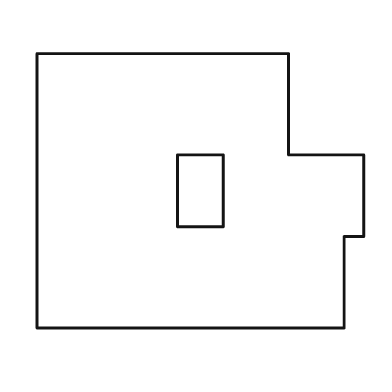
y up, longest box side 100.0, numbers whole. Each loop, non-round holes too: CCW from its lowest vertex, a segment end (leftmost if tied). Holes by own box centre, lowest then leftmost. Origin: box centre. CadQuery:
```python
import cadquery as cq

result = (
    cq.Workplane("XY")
    .moveTo(-50.0, -42.0)
    .lineTo(44.0, -42.0)
    .lineTo(44.0, -14.0)
    .lineTo(50.0, -14.0)
    .lineTo(50.0, 11.0)
    .lineTo(27.0, 11.0)
    .lineTo(27.0, 42.0)
    .lineTo(-50.0, 42.0)
    .close()
    .moveTo(-7.0, -11.0)
    .lineTo(7.0, -11.0)
    .lineTo(7.0, 11.0)
    .lineTo(-7.0, 11.0)
    .close()
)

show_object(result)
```